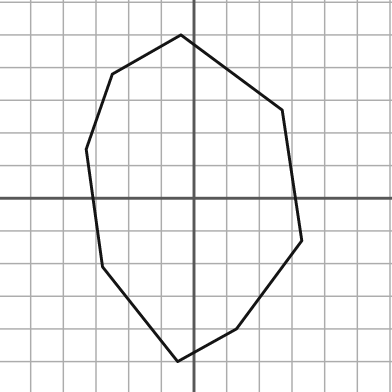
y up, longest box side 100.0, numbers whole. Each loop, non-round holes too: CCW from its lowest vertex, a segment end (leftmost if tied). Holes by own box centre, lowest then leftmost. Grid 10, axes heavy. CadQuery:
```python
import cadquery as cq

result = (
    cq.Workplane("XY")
    .moveTo(-5.0, -50.0)
    .lineTo(13.0, -40.0)
    .lineTo(33.0, -13.0)
    .lineTo(27.0, 27.0)
    .lineTo(-4.0, 50.0)
    .lineTo(-25.0, 38.0)
    .lineTo(-33.0, 15.0)
    .lineTo(-28.0, -21.0)
    .close()
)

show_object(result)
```